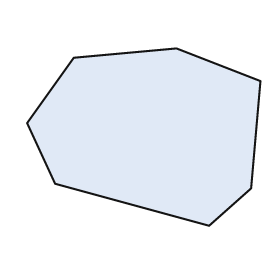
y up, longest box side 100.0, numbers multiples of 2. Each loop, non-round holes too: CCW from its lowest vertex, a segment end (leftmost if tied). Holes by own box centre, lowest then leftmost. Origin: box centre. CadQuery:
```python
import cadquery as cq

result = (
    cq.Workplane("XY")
    .moveTo(28.0, -38.0)
    .lineTo(46.0, -22.0)
    .lineTo(50.0, 24.0)
    .lineTo(14.0, 38.0)
    .lineTo(-30.0, 34.0)
    .lineTo(-50.0, 6.0)
    .lineTo(-38.0, -20.0)
    .close()
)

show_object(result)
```